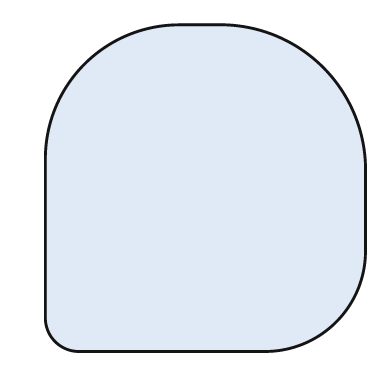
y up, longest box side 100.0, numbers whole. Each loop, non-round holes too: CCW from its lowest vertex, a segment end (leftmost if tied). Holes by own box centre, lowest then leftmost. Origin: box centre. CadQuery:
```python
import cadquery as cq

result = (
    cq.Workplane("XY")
    .moveTo(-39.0, -50.0)
    .lineTo(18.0, -50.0)
    .threePointArc((40.0, -41.0), (49.0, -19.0))
    .lineTo(49.0, 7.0)
    .threePointArc((36.0, 37.0), (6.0, 50.0))
    .lineTo(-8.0, 50.0)
    .threePointArc((-37.0, 38.0), (-49.0, 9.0))
    .lineTo(-49.0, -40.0)
    .threePointArc((-46.0, -47.0), (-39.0, -50.0))
    .close()
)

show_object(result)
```